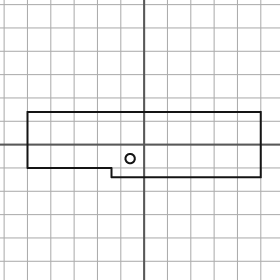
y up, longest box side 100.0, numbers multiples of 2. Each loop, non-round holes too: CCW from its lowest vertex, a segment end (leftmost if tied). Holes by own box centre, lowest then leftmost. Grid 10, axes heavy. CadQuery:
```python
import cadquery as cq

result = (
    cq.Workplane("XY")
    .moveTo(-14.0, -14.0)
    .lineTo(50.0, -14.0)
    .lineTo(50.0, 14.0)
    .lineTo(-50.0, 14.0)
    .lineTo(-50.0, -10.0)
    .lineTo(-14.0, -10.0)
    .close()
    .moveTo(-6.0, -6.0)
    .circle(2.0)
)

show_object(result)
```